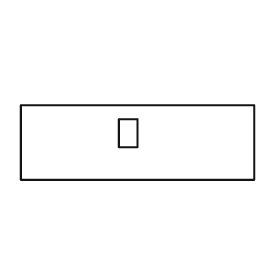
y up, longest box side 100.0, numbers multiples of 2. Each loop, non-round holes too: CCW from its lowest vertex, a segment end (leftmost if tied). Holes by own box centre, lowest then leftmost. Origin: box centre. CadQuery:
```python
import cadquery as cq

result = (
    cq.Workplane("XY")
    .moveTo(-50.0, -16.0)
    .lineTo(50.0, -16.0)
    .lineTo(50.0, 16.0)
    .lineTo(-50.0, 16.0)
    .close()
    .moveTo(-8.0, -2.0)
    .lineTo(0.0, -2.0)
    .lineTo(0.0, 10.0)
    .lineTo(-8.0, 10.0)
    .close()
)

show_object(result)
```